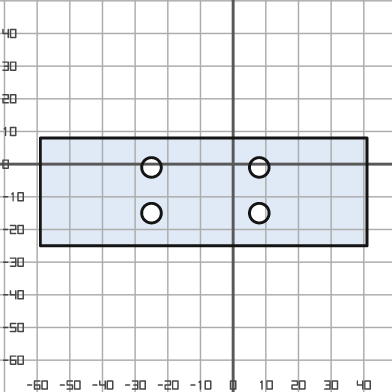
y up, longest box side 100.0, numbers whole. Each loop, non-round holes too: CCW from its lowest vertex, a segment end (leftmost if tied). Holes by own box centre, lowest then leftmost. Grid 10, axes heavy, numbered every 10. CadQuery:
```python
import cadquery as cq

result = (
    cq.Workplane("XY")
    .moveTo(-59.0, -25.0)
    .lineTo(41.0, -25.0)
    .lineTo(41.0, 8.0)
    .lineTo(-59.0, 8.0)
    .close()
    .moveTo(-25.0, -15.0)
    .circle(3.0)
    .moveTo(8.0, -15.0)
    .circle(3.0)
    .moveTo(-25.0, -1.0)
    .circle(3.0)
    .moveTo(8.0, -1.0)
    .circle(3.0)
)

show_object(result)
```